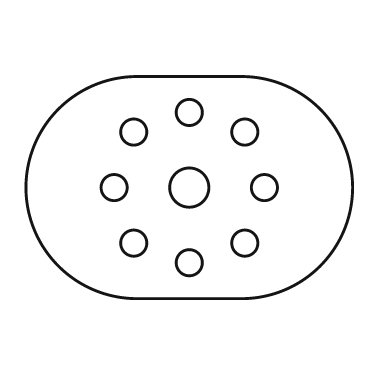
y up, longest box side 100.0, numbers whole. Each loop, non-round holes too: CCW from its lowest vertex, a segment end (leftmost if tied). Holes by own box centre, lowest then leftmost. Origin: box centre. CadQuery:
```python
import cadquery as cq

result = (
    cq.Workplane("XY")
    .moveTo(-16.0, -34.0)
    .lineTo(16.0, -34.0)
    .threePointArc((50.0, 0.0), (16.0, 34.0))
    .lineTo(-16.0, 34.0)
    .threePointArc((-50.0, 0.0), (-16.0, -34.0))
    .close()
    .moveTo(0.0, -23.0)
    .circle(4.0)
    .moveTo(-17.0, -17.0)
    .circle(4.0)
    .moveTo(17.0, -17.0)
    .circle(4.0)
    .moveTo(-23.0, 0.0)
    .circle(4.0)
    .moveTo(0.0, 0.0)
    .circle(6.0)
    .moveTo(23.0, 0.0)
    .circle(4.0)
    .moveTo(-17.0, 17.0)
    .circle(4.0)
    .moveTo(17.0, 17.0)
    .circle(4.0)
    .moveTo(0.0, 23.0)
    .circle(4.0)
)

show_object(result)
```